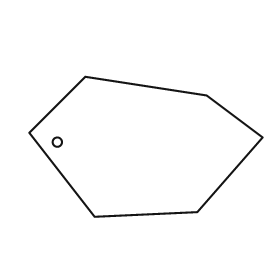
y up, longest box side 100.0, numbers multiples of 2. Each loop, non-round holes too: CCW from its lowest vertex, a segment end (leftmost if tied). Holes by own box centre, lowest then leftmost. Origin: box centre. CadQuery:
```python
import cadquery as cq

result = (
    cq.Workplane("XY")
    .moveTo(-22.0, -30.0)
    .lineTo(22.0, -28.0)
    .lineTo(50.0, 4.0)
    .lineTo(26.0, 22.0)
    .lineTo(-26.0, 30.0)
    .lineTo(-50.0, 6.0)
    .close()
    .moveTo(-38.0, 2.0)
    .circle(2.0)
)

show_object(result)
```